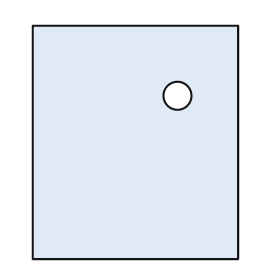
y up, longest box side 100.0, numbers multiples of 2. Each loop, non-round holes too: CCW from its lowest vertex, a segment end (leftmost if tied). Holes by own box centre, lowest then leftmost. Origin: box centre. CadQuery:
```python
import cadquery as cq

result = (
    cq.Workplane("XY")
    .moveTo(-44.0, -50.0)
    .lineTo(44.0, -50.0)
    .lineTo(44.0, 50.0)
    .lineTo(-44.0, 50.0)
    .close()
    .moveTo(18.0, 20.0)
    .circle(6.0)
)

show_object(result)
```